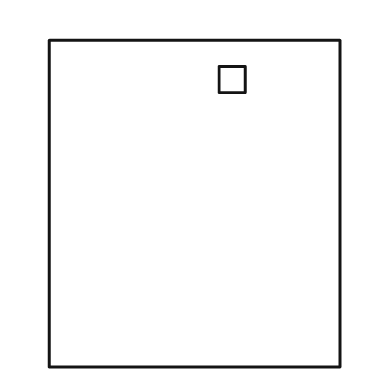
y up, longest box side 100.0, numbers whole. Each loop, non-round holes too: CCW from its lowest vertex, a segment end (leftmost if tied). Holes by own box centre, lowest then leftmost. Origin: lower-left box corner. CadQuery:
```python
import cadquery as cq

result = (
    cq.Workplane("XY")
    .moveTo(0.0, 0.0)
    .lineTo(89.0, 0.0)
    .lineTo(89.0, 100.0)
    .lineTo(0.0, 100.0)
    .close()
    .moveTo(52.0, 84.0)
    .lineTo(60.0, 84.0)
    .lineTo(60.0, 92.0)
    .lineTo(52.0, 92.0)
    .close()
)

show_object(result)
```